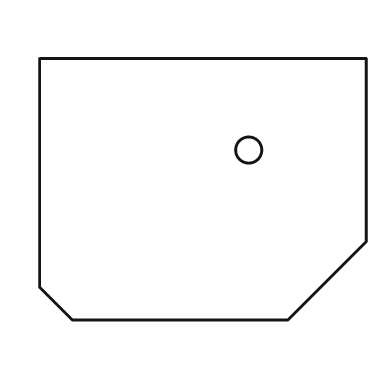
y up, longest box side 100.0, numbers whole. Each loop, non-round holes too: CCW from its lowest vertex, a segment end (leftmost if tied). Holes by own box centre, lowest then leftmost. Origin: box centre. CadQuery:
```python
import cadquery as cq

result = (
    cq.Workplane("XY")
    .moveTo(-40.0, -40.0)
    .lineTo(26.0, -40.0)
    .lineTo(50.0, -16.0)
    .lineTo(50.0, 40.0)
    .lineTo(-50.0, 40.0)
    .lineTo(-50.0, -30.0)
    .close()
    .moveTo(14.0, 12.0)
    .circle(4.0)
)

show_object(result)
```